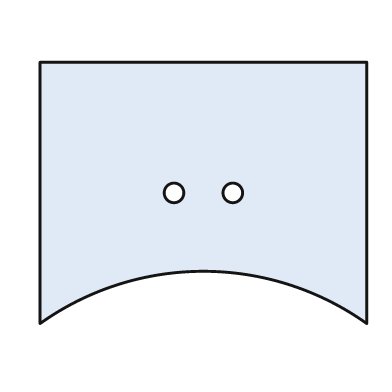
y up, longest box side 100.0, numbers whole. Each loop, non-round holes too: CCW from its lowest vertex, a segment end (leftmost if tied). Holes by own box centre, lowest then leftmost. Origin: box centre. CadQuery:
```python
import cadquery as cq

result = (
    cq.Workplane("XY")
    .moveTo(-50.0, -40.0)
    .threePointArc((0.0, -24.0), (50.0, -40.0))
    .lineTo(50.0, 40.0)
    .lineTo(-50.0, 40.0)
    .close()
    .moveTo(-9.0, 0.0)
    .circle(3.0)
    .moveTo(9.0, 0.0)
    .circle(3.0)
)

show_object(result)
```